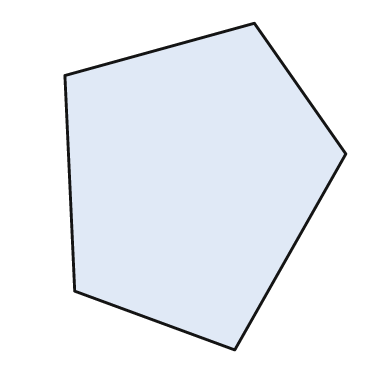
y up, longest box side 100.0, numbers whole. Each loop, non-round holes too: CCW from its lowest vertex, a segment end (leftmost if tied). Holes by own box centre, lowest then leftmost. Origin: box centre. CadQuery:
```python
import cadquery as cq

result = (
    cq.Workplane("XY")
    .moveTo(9.0, -50.0)
    .lineTo(43.0, 10.0)
    .lineTo(15.0, 50.0)
    .lineTo(-43.0, 34.0)
    .lineTo(-40.0, -32.0)
    .close()
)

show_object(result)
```